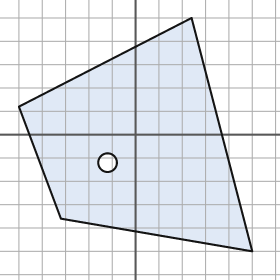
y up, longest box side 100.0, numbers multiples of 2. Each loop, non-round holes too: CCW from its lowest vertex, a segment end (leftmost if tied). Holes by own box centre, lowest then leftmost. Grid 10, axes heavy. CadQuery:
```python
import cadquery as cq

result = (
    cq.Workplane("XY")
    .moveTo(50.0, -50.0)
    .lineTo(24.0, 50.0)
    .lineTo(-50.0, 12.0)
    .lineTo(-32.0, -36.0)
    .close()
    .moveTo(-12.0, -12.0)
    .circle(4.0)
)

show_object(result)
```